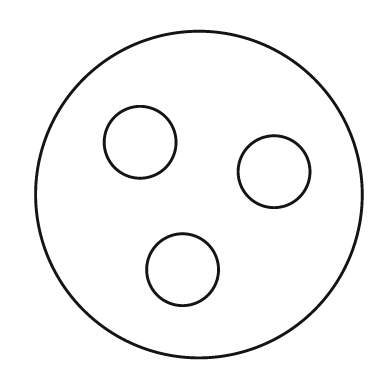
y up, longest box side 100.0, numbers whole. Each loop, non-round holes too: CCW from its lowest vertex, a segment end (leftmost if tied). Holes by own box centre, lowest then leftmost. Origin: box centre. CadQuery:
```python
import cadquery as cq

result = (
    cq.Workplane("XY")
    .moveTo(0.0, 0.0)
    .circle(50.0)
    .moveTo(-5.0, -23.0)
    .circle(11.0)
    .moveTo(23.0, 7.0)
    .circle(11.0)
    .moveTo(-18.0, 16.0)
    .circle(11.0)
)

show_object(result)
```